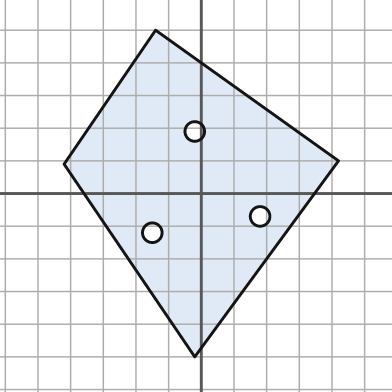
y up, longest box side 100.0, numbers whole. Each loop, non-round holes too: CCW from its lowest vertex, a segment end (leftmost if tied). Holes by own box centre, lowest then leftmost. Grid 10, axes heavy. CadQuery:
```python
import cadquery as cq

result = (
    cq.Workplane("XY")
    .moveTo(-2.0, -50.0)
    .lineTo(42.0, 10.0)
    .lineTo(-14.0, 50.0)
    .lineTo(-42.0, 9.0)
    .close()
    .moveTo(-15.0, -12.0)
    .circle(3.0)
    .moveTo(18.0, -7.0)
    .circle(3.0)
    .moveTo(-2.0, 19.0)
    .circle(3.0)
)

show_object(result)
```